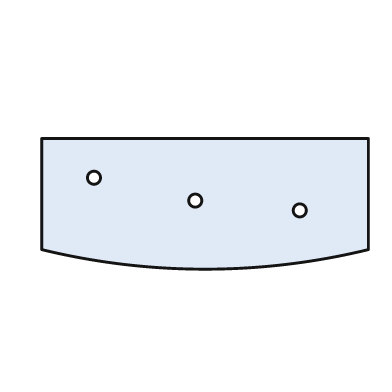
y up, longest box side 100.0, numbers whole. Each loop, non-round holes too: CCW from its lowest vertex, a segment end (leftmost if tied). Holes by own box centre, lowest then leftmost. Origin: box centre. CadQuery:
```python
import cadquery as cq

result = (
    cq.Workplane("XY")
    .moveTo(-50.0, -14.0)
    .threePointArc((0.0, -20.0), (50.0, -14.0))
    .lineTo(50.0, 20.0)
    .lineTo(-50.0, 20.0)
    .close()
    .moveTo(29.0, -2.0)
    .circle(2.0)
    .moveTo(-3.0, 1.0)
    .circle(2.0)
    .moveTo(-34.0, 8.0)
    .circle(2.0)
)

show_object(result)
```